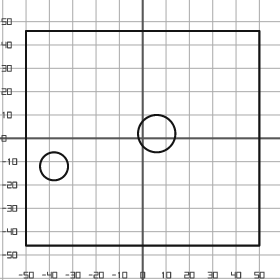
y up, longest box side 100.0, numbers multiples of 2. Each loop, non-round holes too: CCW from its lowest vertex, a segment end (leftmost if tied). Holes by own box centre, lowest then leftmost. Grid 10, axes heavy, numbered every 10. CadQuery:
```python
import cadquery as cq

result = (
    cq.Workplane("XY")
    .moveTo(-50.0, -46.0)
    .lineTo(50.0, -46.0)
    .lineTo(50.0, 46.0)
    .lineTo(-50.0, 46.0)
    .close()
    .moveTo(-38.0, -12.0)
    .circle(6.0)
    .moveTo(6.0, 2.0)
    .circle(8.0)
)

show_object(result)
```